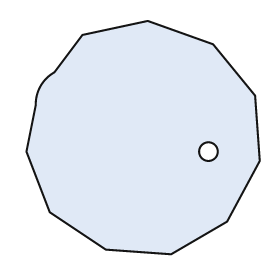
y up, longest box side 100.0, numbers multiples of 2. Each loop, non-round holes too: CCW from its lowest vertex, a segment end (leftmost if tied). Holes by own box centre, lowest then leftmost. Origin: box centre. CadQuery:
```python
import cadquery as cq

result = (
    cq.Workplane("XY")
    .moveTo(12.0, -50.0)
    .lineTo(36.0, -36.0)
    .lineTo(50.0, -10.0)
    .lineTo(48.0, 18.0)
    .lineTo(30.0, 40.0)
    .lineTo(2.0, 50.0)
    .lineTo(-26.0, 44.0)
    .lineTo(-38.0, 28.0)
    .threePointArc((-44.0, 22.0), (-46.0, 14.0))
    .lineTo(-50.0, -6.0)
    .lineTo(-40.0, -32.0)
    .lineTo(-16.0, -48.0)
    .close()
    .moveTo(28.0, -6.0)
    .circle(4.0)
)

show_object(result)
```